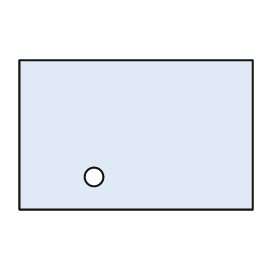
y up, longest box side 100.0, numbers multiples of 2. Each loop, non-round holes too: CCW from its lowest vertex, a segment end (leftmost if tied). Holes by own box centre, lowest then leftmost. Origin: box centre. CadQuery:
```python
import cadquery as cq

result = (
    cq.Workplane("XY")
    .moveTo(-50.0, -32.0)
    .lineTo(50.0, -32.0)
    .lineTo(50.0, 32.0)
    .lineTo(-50.0, 32.0)
    .close()
    .moveTo(-18.0, -18.0)
    .circle(4.0)
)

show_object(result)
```